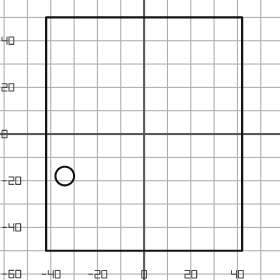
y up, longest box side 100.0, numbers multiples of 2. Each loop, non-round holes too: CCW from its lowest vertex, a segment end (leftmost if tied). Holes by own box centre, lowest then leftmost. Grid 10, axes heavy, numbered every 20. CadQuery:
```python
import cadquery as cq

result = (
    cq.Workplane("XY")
    .moveTo(-42.0, -50.0)
    .lineTo(42.0, -50.0)
    .lineTo(42.0, 50.0)
    .lineTo(-42.0, 50.0)
    .close()
    .moveTo(-34.0, -18.0)
    .circle(4.0)
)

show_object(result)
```